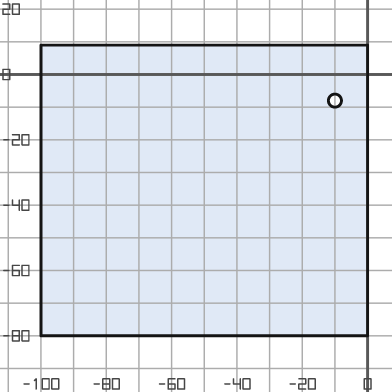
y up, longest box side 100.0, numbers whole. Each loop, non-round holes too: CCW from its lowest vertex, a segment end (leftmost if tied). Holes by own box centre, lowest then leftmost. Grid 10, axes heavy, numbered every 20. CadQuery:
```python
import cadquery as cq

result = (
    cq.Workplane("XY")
    .moveTo(-100.0, -80.0)
    .lineTo(0.0, -80.0)
    .lineTo(0.0, 9.0)
    .lineTo(-100.0, 9.0)
    .close()
    .moveTo(-10.0, -8.0)
    .circle(2.0)
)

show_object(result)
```